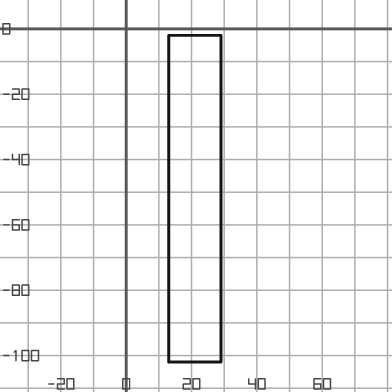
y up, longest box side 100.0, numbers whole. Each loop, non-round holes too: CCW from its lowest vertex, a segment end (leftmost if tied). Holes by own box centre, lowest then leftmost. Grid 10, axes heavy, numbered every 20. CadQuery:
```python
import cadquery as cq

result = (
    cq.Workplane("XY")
    .moveTo(13.0, -102.0)
    .lineTo(29.0, -102.0)
    .lineTo(29.0, -2.0)
    .lineTo(13.0, -2.0)
    .close()
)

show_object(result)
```